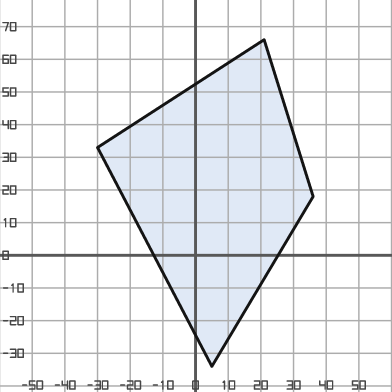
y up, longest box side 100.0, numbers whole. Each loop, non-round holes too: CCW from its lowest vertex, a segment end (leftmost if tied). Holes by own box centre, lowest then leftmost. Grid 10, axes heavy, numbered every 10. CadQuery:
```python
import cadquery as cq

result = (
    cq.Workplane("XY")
    .moveTo(5.0, -34.0)
    .lineTo(36.0, 18.0)
    .lineTo(21.0, 66.0)
    .lineTo(-30.0, 33.0)
    .close()
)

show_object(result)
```